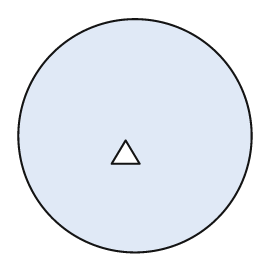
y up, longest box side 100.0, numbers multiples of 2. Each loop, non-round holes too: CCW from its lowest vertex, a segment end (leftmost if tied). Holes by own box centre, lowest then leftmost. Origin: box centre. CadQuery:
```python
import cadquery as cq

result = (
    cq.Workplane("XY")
    .moveTo(0.0, 0.0)
    .circle(50.0)
    .moveTo(-10.0, -12.0)
    .lineTo(2.0, -12.0)
    .lineTo(-4.0, -2.0)
    .close()
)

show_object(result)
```